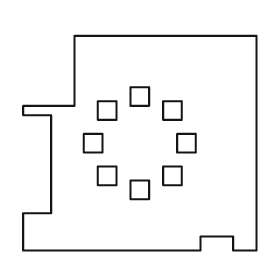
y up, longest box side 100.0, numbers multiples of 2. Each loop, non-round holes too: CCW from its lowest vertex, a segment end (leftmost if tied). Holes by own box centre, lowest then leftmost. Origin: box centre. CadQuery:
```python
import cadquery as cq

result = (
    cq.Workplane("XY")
    .moveTo(-50.0, -46.0)
    .lineTo(26.0, -46.0)
    .lineTo(26.0, -40.0)
    .lineTo(40.0, -40.0)
    .lineTo(40.0, -46.0)
    .lineTo(50.0, -46.0)
    .lineTo(50.0, 46.0)
    .lineTo(-28.0, 46.0)
    .lineTo(-28.0, 16.0)
    .lineTo(-50.0, 16.0)
    .lineTo(-50.0, 12.0)
    .lineTo(-38.0, 12.0)
    .lineTo(-38.0, -30.0)
    .lineTo(-50.0, -30.0)
    .close()
    .moveTo(-4.0, -24.0)
    .lineTo(4.0, -24.0)
    .lineTo(4.0, -16.0)
    .lineTo(-4.0, -16.0)
    .close()
    .moveTo(-18.0, -18.0)
    .lineTo(-10.0, -18.0)
    .lineTo(-10.0, -10.0)
    .lineTo(-18.0, -10.0)
    .close()
    .moveTo(10.0, -18.0)
    .lineTo(18.0, -18.0)
    .lineTo(18.0, -10.0)
    .lineTo(10.0, -10.0)
    .close()
    .moveTo(-24.0, -4.0)
    .lineTo(-16.0, -4.0)
    .lineTo(-16.0, 4.0)
    .lineTo(-24.0, 4.0)
    .close()
    .moveTo(16.0, -4.0)
    .lineTo(24.0, -4.0)
    .lineTo(24.0, 4.0)
    .lineTo(16.0, 4.0)
    .close()
    .moveTo(-18.0, 10.0)
    .lineTo(-10.0, 10.0)
    .lineTo(-10.0, 18.0)
    .lineTo(-18.0, 18.0)
    .close()
    .moveTo(10.0, 10.0)
    .lineTo(18.0, 10.0)
    .lineTo(18.0, 18.0)
    .lineTo(10.0, 18.0)
    .close()
    .moveTo(-4.0, 16.0)
    .lineTo(4.0, 16.0)
    .lineTo(4.0, 24.0)
    .lineTo(-4.0, 24.0)
    .close()
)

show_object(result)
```